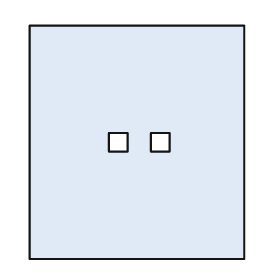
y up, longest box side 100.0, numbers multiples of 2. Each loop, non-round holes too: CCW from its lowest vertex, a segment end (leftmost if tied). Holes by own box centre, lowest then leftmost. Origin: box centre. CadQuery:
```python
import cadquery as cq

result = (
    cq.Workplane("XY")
    .moveTo(-46.0, -50.0)
    .lineTo(46.0, -50.0)
    .lineTo(46.0, 50.0)
    .lineTo(-46.0, 50.0)
    .close()
    .moveTo(-12.0, -4.0)
    .lineTo(-4.0, -4.0)
    .lineTo(-4.0, 4.0)
    .lineTo(-12.0, 4.0)
    .close()
    .moveTo(6.0, -4.0)
    .lineTo(14.0, -4.0)
    .lineTo(14.0, 4.0)
    .lineTo(6.0, 4.0)
    .close()
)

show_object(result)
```